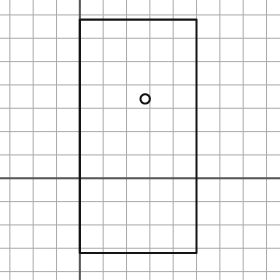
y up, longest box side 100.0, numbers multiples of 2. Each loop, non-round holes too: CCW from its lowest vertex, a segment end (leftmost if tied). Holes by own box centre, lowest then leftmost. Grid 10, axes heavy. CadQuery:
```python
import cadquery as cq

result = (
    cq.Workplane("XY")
    .moveTo(0.0, -32.0)
    .lineTo(50.0, -32.0)
    .lineTo(50.0, 68.0)
    .lineTo(0.0, 68.0)
    .close()
    .moveTo(28.0, 34.0)
    .circle(2.0)
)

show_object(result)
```